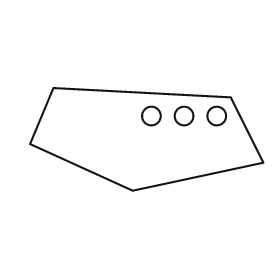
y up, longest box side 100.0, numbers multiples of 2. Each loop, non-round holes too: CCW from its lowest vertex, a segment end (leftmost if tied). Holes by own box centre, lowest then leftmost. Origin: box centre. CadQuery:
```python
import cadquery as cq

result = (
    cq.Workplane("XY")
    .moveTo(-6.0, -22.0)
    .lineTo(50.0, -10.0)
    .lineTo(36.0, 18.0)
    .lineTo(-40.0, 22.0)
    .lineTo(-50.0, -2.0)
    .close()
    .moveTo(2.0, 10.0)
    .circle(4.0)
    .moveTo(16.0, 10.0)
    .circle(4.0)
    .moveTo(30.0, 10.0)
    .circle(4.0)
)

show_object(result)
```